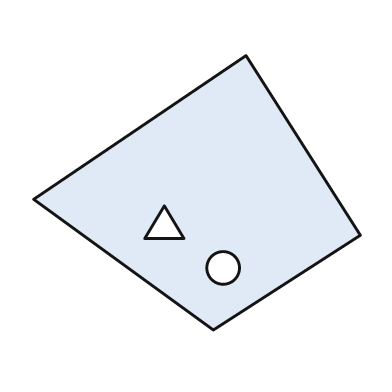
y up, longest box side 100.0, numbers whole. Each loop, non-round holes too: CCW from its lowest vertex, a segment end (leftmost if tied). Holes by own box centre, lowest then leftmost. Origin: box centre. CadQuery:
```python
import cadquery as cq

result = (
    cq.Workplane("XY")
    .moveTo(5.0, -42.0)
    .lineTo(50.0, -13.0)
    .lineTo(15.0, 42.0)
    .lineTo(-50.0, -2.0)
    .close()
    .moveTo(8.0, -23.0)
    .circle(5.0)
    .moveTo(-16.0, -14.0)
    .lineTo(-4.0, -14.0)
    .lineTo(-10.0, -4.0)
    .close()
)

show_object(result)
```